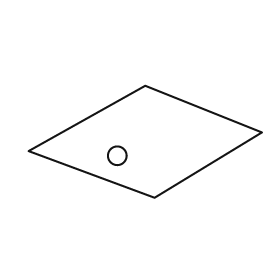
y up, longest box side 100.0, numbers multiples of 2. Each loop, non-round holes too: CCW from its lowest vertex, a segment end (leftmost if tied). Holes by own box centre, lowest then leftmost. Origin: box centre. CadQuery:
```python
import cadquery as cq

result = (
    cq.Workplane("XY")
    .moveTo(4.0, -24.0)
    .lineTo(50.0, 4.0)
    .lineTo(0.0, 24.0)
    .lineTo(-50.0, -4.0)
    .close()
    .moveTo(-12.0, -6.0)
    .circle(4.0)
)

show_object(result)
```